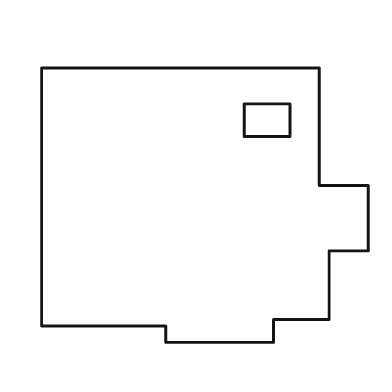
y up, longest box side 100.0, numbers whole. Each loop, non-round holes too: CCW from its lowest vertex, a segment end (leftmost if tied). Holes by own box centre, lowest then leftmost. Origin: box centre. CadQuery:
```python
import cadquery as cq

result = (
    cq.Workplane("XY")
    .moveTo(-12.0, -42.0)
    .lineTo(21.0, -42.0)
    .lineTo(21.0, -35.0)
    .lineTo(38.0, -35.0)
    .lineTo(38.0, -14.0)
    .lineTo(50.0, -14.0)
    .lineTo(50.0, 6.0)
    .lineTo(35.0, 6.0)
    .lineTo(35.0, 42.0)
    .lineTo(-50.0, 42.0)
    .lineTo(-50.0, -37.0)
    .lineTo(-12.0, -37.0)
    .close()
    .moveTo(12.0, 21.0)
    .lineTo(26.0, 21.0)
    .lineTo(26.0, 31.0)
    .lineTo(12.0, 31.0)
    .close()
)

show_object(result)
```